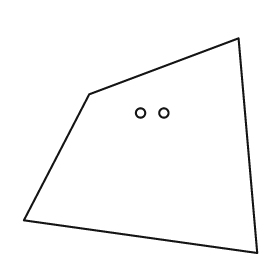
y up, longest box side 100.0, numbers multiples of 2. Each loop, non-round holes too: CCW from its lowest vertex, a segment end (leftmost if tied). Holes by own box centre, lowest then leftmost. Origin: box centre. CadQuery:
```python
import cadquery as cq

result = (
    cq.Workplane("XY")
    .moveTo(50.0, -46.0)
    .lineTo(42.0, 46.0)
    .lineTo(-22.0, 22.0)
    .lineTo(-50.0, -32.0)
    .close()
    .moveTo(0.0, 14.0)
    .circle(2.0)
    .moveTo(10.0, 14.0)
    .circle(2.0)
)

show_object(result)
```